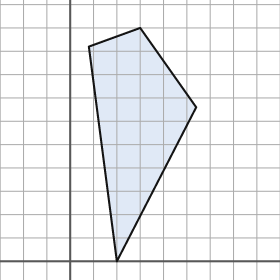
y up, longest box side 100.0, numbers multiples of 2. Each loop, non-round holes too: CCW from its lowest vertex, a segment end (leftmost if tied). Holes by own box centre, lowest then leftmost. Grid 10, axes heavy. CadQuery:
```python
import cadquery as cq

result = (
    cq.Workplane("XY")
    .moveTo(20.0, 0.0)
    .lineTo(54.0, 66.0)
    .lineTo(30.0, 100.0)
    .lineTo(8.0, 92.0)
    .close()
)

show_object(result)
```